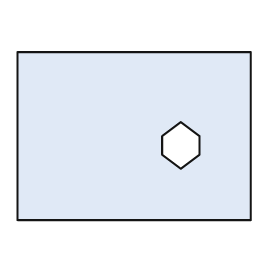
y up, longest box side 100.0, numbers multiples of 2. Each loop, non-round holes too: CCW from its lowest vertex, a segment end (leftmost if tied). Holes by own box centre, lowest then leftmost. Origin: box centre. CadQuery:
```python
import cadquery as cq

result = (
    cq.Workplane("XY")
    .moveTo(-50.0, -36.0)
    .lineTo(50.0, -36.0)
    .lineTo(50.0, 36.0)
    .lineTo(-50.0, 36.0)
    .close()
    .moveTo(20.0, -14.0)
    .lineTo(28.0, -8.0)
    .lineTo(28.0, 0.0)
    .lineTo(20.0, 6.0)
    .lineTo(12.0, 0.0)
    .lineTo(12.0, -8.0)
    .close()
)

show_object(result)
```